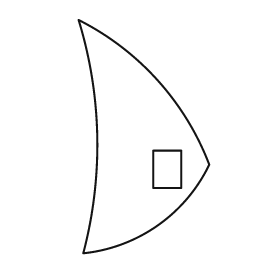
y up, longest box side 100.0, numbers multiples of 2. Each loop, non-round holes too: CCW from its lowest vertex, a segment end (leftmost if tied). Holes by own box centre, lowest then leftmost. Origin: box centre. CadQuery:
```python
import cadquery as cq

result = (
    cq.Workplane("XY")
    .moveTo(-26.0, -50.0)
    .threePointArc((6.0, -38.0), (28.0, -12.0))
    .threePointArc((6.0, 24.0), (-28.0, 50.0))
    .threePointArc((-20.0, 0.0), (-26.0, -50.0))
    .close()
    .moveTo(4.0, -22.0)
    .lineTo(16.0, -22.0)
    .lineTo(16.0, -6.0)
    .lineTo(4.0, -6.0)
    .close()
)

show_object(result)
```